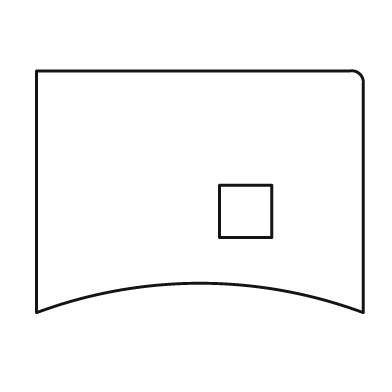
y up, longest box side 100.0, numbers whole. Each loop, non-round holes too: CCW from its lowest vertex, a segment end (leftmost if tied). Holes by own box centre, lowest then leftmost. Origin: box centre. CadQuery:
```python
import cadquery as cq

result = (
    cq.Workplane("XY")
    .moveTo(-50.0, -37.0)
    .threePointArc((0.0, -28.0), (50.0, -37.0))
    .lineTo(50.0, 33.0)
    .threePointArc((49.0, 36.0), (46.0, 37.0))
    .lineTo(-50.0, 37.0)
    .close()
    .moveTo(6.0, -14.0)
    .lineTo(22.0, -14.0)
    .lineTo(22.0, 2.0)
    .lineTo(6.0, 2.0)
    .close()
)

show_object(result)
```